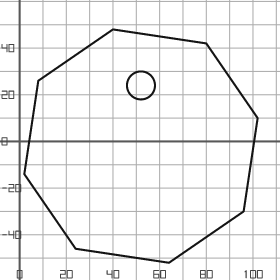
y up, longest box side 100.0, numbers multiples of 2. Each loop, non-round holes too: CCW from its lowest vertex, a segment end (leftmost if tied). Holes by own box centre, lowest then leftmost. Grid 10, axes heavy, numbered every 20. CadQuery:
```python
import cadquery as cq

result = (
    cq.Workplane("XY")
    .moveTo(64.0, -52.0)
    .lineTo(96.0, -30.0)
    .lineTo(102.0, 10.0)
    .lineTo(80.0, 42.0)
    .lineTo(40.0, 48.0)
    .lineTo(8.0, 26.0)
    .lineTo(2.0, -14.0)
    .lineTo(24.0, -46.0)
    .close()
    .moveTo(52.0, 24.0)
    .circle(6.0)
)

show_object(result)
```